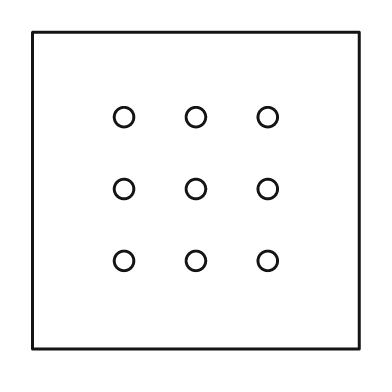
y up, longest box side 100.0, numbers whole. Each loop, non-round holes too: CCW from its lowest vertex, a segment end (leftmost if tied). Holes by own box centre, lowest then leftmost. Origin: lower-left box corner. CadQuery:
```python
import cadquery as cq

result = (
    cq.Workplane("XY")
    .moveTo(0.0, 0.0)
    .lineTo(100.0, 0.0)
    .lineTo(100.0, 97.0)
    .lineTo(0.0, 97.0)
    .close()
    .moveTo(28.0, 27.0)
    .circle(3.0)
    .moveTo(50.0, 27.0)
    .circle(3.0)
    .moveTo(72.0, 27.0)
    .circle(3.0)
    .moveTo(28.0, 49.0)
    .circle(3.0)
    .moveTo(50.0, 49.0)
    .circle(3.0)
    .moveTo(72.0, 49.0)
    .circle(3.0)
    .moveTo(28.0, 71.0)
    .circle(3.0)
    .moveTo(50.0, 71.0)
    .circle(3.0)
    .moveTo(72.0, 71.0)
    .circle(3.0)
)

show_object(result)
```